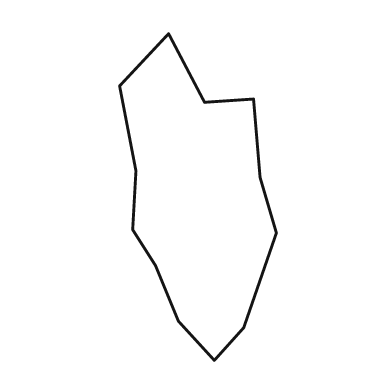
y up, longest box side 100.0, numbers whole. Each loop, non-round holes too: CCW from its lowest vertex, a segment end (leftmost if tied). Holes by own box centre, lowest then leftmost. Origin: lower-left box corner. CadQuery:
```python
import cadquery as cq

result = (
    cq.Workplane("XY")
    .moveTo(29.0, 0.0)
    .lineTo(38.0, 10.0)
    .lineTo(48.0, 39.0)
    .lineTo(43.0, 56.0)
    .lineTo(41.0, 80.0)
    .lineTo(26.0, 79.0)
    .lineTo(15.0, 100.0)
    .lineTo(0.0, 84.0)
    .lineTo(5.0, 58.0)
    .lineTo(4.0, 40.0)
    .lineTo(11.0, 29.0)
    .lineTo(18.0, 12.0)
    .close()
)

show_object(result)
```